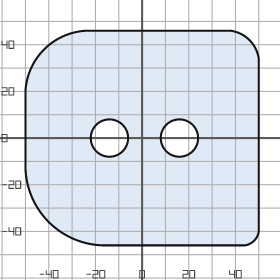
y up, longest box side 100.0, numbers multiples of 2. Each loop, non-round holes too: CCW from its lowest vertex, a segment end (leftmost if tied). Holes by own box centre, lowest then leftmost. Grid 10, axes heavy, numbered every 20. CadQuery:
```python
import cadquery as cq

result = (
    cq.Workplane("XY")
    .moveTo(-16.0, -46.0)
    .lineTo(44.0, -46.0)
    .threePointArc((48.0, -44.0), (50.0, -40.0))
    .lineTo(50.0, 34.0)
    .threePointArc((46.0, 42.0), (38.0, 46.0))
    .lineTo(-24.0, 46.0)
    .threePointArc((-42.0, 38.0), (-50.0, 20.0))
    .lineTo(-50.0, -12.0)
    .threePointArc((-40.0, -36.0), (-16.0, -46.0))
    .close()
    .moveTo(-14.0, 0.0)
    .circle(8.0)
    .moveTo(16.0, 0.0)
    .circle(8.0)
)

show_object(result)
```